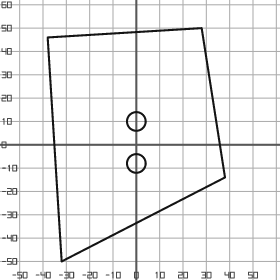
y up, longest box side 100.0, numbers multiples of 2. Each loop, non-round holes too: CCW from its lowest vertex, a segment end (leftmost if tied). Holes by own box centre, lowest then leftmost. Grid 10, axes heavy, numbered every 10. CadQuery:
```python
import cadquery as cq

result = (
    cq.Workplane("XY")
    .moveTo(-32.0, -50.0)
    .lineTo(38.0, -14.0)
    .lineTo(28.0, 50.0)
    .lineTo(-38.0, 46.0)
    .close()
    .moveTo(0.0, -8.0)
    .circle(4.0)
    .moveTo(0.0, 10.0)
    .circle(4.0)
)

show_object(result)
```